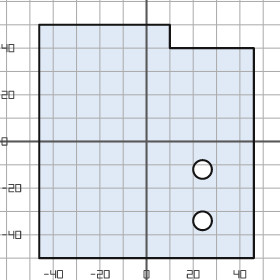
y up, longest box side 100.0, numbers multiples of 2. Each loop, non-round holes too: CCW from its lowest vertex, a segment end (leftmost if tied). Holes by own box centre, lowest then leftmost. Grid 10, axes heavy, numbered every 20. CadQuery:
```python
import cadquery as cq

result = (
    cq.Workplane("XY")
    .moveTo(-46.0, -50.0)
    .lineTo(46.0, -50.0)
    .lineTo(46.0, 40.0)
    .lineTo(10.0, 40.0)
    .lineTo(10.0, 50.0)
    .lineTo(-46.0, 50.0)
    .close()
    .moveTo(24.0, -34.0)
    .circle(4.0)
    .moveTo(24.0, -12.0)
    .circle(4.0)
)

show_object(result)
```